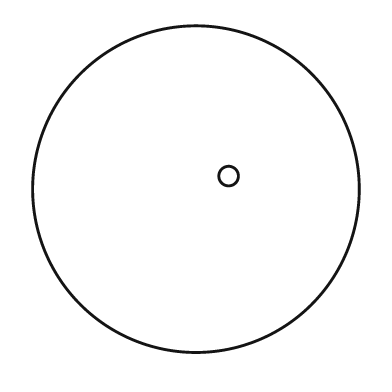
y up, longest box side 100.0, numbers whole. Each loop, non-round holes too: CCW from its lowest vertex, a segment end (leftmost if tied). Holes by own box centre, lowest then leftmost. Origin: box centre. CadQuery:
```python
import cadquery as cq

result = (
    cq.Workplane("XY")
    .moveTo(0.0, 0.0)
    .circle(50.0)
    .moveTo(10.0, 4.0)
    .circle(3.0)
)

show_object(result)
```